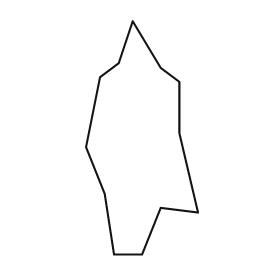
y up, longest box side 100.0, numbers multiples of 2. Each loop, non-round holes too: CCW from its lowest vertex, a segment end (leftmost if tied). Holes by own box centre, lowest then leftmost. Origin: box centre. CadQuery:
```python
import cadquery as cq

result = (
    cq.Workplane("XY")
    .moveTo(-12.0, -50.0)
    .lineTo(0.0, -50.0)
    .lineTo(8.0, -30.0)
    .lineTo(24.0, -32.0)
    .lineTo(16.0, 2.0)
    .lineTo(16.0, 24.0)
    .lineTo(8.0, 30.0)
    .lineTo(-4.0, 50.0)
    .lineTo(-10.0, 32.0)
    .lineTo(-18.0, 26.0)
    .lineTo(-24.0, -4.0)
    .lineTo(-16.0, -24.0)
    .close()
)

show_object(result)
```